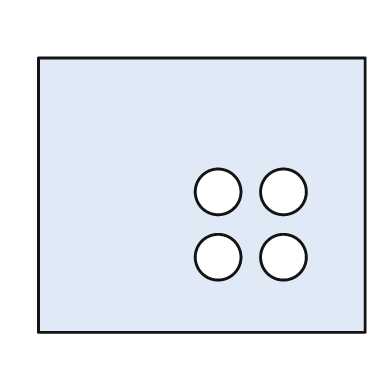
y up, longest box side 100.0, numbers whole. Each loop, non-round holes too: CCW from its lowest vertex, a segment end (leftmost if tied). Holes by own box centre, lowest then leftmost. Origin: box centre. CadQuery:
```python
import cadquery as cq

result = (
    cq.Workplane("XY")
    .moveTo(-50.0, -42.0)
    .lineTo(50.0, -42.0)
    .lineTo(50.0, 42.0)
    .lineTo(-50.0, 42.0)
    .close()
    .moveTo(5.0, -19.0)
    .circle(7.0)
    .moveTo(25.0, -19.0)
    .circle(7.0)
    .moveTo(5.0, 1.0)
    .circle(7.0)
    .moveTo(25.0, 1.0)
    .circle(7.0)
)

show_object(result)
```